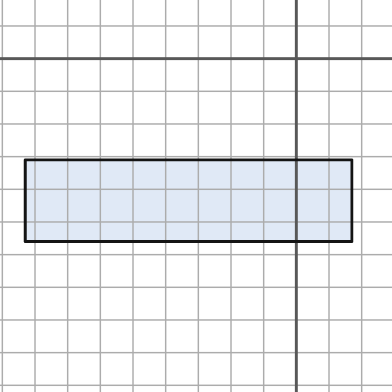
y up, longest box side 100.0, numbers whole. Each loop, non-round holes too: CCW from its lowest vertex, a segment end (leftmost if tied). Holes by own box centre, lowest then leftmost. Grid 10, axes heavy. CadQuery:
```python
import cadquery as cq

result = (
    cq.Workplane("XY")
    .moveTo(-83.0, -56.0)
    .lineTo(17.0, -56.0)
    .lineTo(17.0, -31.0)
    .lineTo(-83.0, -31.0)
    .close()
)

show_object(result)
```